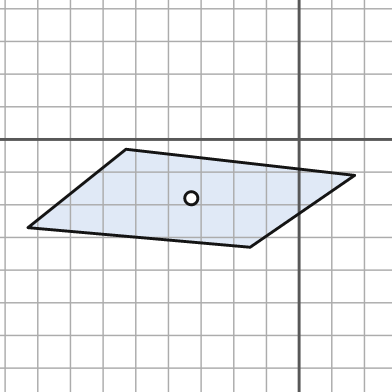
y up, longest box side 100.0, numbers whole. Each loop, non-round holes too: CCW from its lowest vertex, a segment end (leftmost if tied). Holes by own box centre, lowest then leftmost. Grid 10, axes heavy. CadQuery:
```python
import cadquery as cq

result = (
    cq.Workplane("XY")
    .moveTo(-15.0, -33.0)
    .lineTo(17.0, -11.0)
    .lineTo(-53.0, -3.0)
    .lineTo(-83.0, -27.0)
    .close()
    .moveTo(-33.0, -18.0)
    .circle(2.0)
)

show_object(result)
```